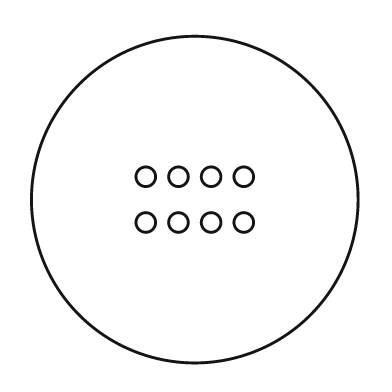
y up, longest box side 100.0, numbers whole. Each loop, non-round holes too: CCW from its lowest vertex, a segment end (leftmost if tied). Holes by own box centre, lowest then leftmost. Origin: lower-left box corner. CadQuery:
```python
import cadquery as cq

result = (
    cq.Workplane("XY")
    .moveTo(50.0, 50.0)
    .circle(50.0)
    .moveTo(35.0, 43.0)
    .circle(3.0)
    .moveTo(45.0, 43.0)
    .circle(3.0)
    .moveTo(55.0, 43.0)
    .circle(3.0)
    .moveTo(65.0, 43.0)
    .circle(3.0)
    .moveTo(35.0, 57.0)
    .circle(3.0)
    .moveTo(45.0, 57.0)
    .circle(3.0)
    .moveTo(55.0, 57.0)
    .circle(3.0)
    .moveTo(65.0, 57.0)
    .circle(3.0)
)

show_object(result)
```